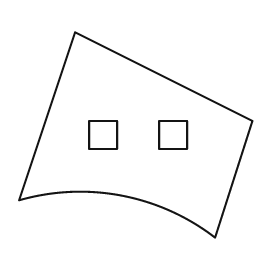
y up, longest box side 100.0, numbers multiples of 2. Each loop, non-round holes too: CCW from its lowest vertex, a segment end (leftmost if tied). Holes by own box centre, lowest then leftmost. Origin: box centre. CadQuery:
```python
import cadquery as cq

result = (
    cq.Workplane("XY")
    .moveTo(34.0, -44.0)
    .lineTo(50.0, 6.0)
    .lineTo(-26.0, 44.0)
    .lineTo(-50.0, -28.0)
    .threePointArc((-6.0, -26.0), (34.0, -44.0))
    .close()
    .moveTo(-20.0, -6.0)
    .lineTo(-8.0, -6.0)
    .lineTo(-8.0, 6.0)
    .lineTo(-20.0, 6.0)
    .close()
    .moveTo(10.0, -6.0)
    .lineTo(22.0, -6.0)
    .lineTo(22.0, 6.0)
    .lineTo(10.0, 6.0)
    .close()
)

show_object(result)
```